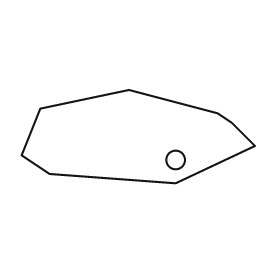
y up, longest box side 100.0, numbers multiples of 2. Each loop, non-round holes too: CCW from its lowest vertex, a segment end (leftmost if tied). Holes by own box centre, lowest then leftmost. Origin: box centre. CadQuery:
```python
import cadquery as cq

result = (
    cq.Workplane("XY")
    .moveTo(16.0, -20.0)
    .lineTo(50.0, -4.0)
    .lineTo(40.0, 6.0)
    .lineTo(34.0, 10.0)
    .lineTo(-4.0, 20.0)
    .lineTo(-42.0, 12.0)
    .lineTo(-50.0, -8.0)
    .lineTo(-38.0, -16.0)
    .close()
    .moveTo(16.0, -10.0)
    .circle(4.0)
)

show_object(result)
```